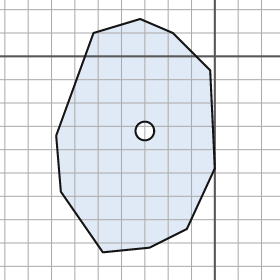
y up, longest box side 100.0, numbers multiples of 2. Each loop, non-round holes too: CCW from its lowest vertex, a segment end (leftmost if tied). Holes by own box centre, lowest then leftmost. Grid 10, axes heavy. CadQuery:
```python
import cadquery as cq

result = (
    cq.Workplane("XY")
    .moveTo(-48.0, -84.0)
    .lineTo(-28.0, -82.0)
    .lineTo(-12.0, -74.0)
    .lineTo(0.0, -48.0)
    .lineTo(-2.0, -6.0)
    .lineTo(-18.0, 10.0)
    .lineTo(-32.0, 16.0)
    .lineTo(-52.0, 10.0)
    .lineTo(-68.0, -34.0)
    .lineTo(-66.0, -58.0)
    .close()
    .moveTo(-30.0, -32.0)
    .circle(4.0)
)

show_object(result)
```